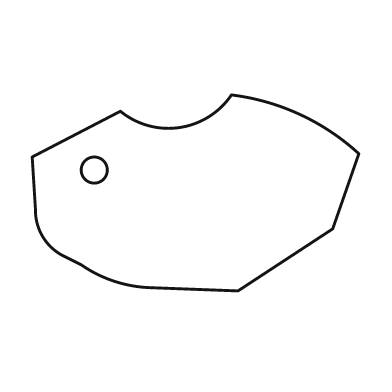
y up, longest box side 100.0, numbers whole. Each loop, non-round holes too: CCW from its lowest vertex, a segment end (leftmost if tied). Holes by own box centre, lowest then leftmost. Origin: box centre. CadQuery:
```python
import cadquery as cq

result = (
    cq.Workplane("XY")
    .moveTo(13.0, -30.0)
    .lineTo(42.0, -11.0)
    .lineTo(50.0, 12.0)
    .threePointArc((32.0, 24.0), (11.0, 30.0))
    .threePointArc((-5.0, 20.0), (-23.0, 25.0))
    .lineTo(-50.0, 11.0)
    .lineTo(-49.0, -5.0)
    .threePointArc((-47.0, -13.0), (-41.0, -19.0))
    .lineTo(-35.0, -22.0)
    .threePointArc((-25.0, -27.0), (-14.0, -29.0))
    .close()
    .moveTo(-31.0, 7.0)
    .circle(4.0)
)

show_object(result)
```